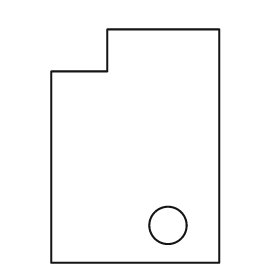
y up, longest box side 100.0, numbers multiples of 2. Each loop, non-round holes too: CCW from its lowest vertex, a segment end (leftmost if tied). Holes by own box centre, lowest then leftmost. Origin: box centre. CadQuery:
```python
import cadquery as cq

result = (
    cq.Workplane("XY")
    .moveTo(-36.0, -50.0)
    .lineTo(36.0, -50.0)
    .lineTo(36.0, 50.0)
    .lineTo(-12.0, 50.0)
    .lineTo(-12.0, 32.0)
    .lineTo(-36.0, 32.0)
    .close()
    .moveTo(14.0, -34.0)
    .circle(8.0)
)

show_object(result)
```